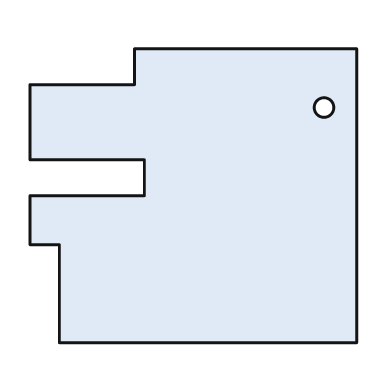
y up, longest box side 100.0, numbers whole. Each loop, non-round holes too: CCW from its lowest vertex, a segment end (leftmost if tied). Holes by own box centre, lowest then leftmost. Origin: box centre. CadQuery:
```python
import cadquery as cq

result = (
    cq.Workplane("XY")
    .moveTo(-41.0, -45.0)
    .lineTo(50.0, -45.0)
    .lineTo(50.0, 45.0)
    .lineTo(-18.0, 45.0)
    .lineTo(-18.0, 34.0)
    .lineTo(-50.0, 34.0)
    .lineTo(-50.0, 11.0)
    .lineTo(-15.0, 11.0)
    .lineTo(-15.0, 0.0)
    .lineTo(-50.0, 0.0)
    .lineTo(-50.0, -15.0)
    .lineTo(-41.0, -15.0)
    .close()
    .moveTo(40.0, 27.0)
    .circle(3.0)
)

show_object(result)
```